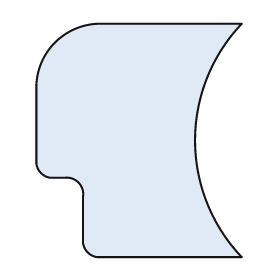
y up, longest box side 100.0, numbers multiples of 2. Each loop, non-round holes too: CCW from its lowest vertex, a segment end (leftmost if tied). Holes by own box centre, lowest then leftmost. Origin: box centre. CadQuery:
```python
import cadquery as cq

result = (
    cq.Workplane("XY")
    .moveTo(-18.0, -50.0)
    .lineTo(44.0, -50.0)
    .threePointArc((24.0, 0.0), (44.0, 50.0))
    .lineTo(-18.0, 50.0)
    .threePointArc((-36.0, 42.0), (-44.0, 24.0))
    .lineTo(-44.0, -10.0)
    .threePointArc((-42.0, -14.0), (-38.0, -16.0))
    .lineTo(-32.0, -16.0)
    .threePointArc((-26.0, -18.0), (-24.0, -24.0))
    .lineTo(-24.0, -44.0)
    .threePointArc((-22.0, -48.0), (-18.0, -50.0))
    .close()
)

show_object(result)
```